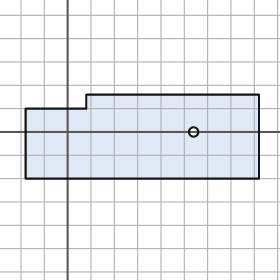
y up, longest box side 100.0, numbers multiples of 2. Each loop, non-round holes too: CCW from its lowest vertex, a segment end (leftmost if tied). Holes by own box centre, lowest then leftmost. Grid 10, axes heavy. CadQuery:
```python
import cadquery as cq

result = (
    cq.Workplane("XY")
    .moveTo(-18.0, -20.0)
    .lineTo(82.0, -20.0)
    .lineTo(82.0, 16.0)
    .lineTo(8.0, 16.0)
    .lineTo(8.0, 10.0)
    .lineTo(-18.0, 10.0)
    .close()
    .moveTo(54.0, 0.0)
    .circle(2.0)
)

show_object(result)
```